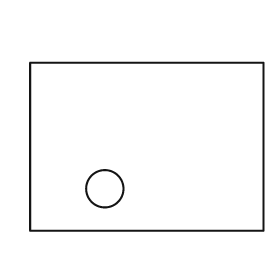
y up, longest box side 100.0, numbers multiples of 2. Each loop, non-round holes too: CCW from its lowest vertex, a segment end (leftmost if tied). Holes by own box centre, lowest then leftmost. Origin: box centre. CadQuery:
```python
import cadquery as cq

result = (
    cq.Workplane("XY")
    .moveTo(-50.0, -36.0)
    .lineTo(50.0, -36.0)
    .lineTo(50.0, 36.0)
    .lineTo(-50.0, 36.0)
    .close()
    .moveTo(-18.0, -18.0)
    .circle(8.0)
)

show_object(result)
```